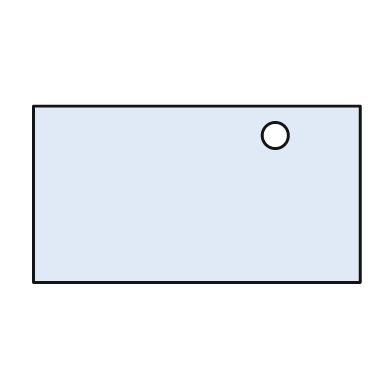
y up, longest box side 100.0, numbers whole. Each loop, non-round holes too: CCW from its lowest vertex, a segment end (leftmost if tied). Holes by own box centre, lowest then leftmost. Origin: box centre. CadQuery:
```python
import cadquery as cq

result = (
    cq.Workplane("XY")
    .moveTo(-50.0, -27.0)
    .lineTo(50.0, -27.0)
    .lineTo(50.0, 27.0)
    .lineTo(-50.0, 27.0)
    .close()
    .moveTo(24.0, 18.0)
    .circle(4.0)
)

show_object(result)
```